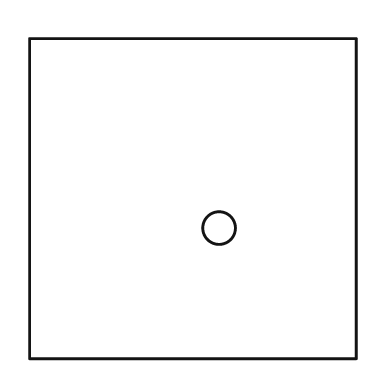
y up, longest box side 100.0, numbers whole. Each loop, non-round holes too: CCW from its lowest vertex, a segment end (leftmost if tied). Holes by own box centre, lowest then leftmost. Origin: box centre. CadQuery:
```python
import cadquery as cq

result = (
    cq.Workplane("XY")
    .moveTo(-50.0, -49.0)
    .lineTo(50.0, -49.0)
    .lineTo(50.0, 49.0)
    .lineTo(-50.0, 49.0)
    .close()
    .moveTo(8.0, -9.0)
    .circle(5.0)
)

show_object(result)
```